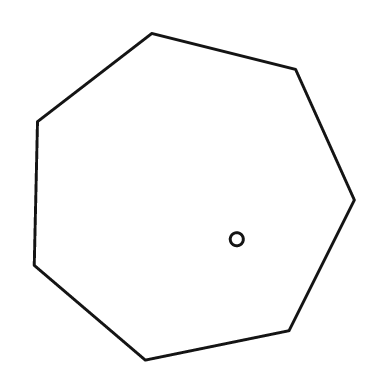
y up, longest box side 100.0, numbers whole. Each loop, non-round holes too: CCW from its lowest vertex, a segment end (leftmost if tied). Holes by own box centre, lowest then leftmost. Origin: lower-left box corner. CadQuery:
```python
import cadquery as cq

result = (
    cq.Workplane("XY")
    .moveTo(34.0, 0.0)
    .lineTo(78.0, 9.0)
    .lineTo(98.0, 49.0)
    .lineTo(80.0, 89.0)
    .lineTo(36.0, 100.0)
    .lineTo(1.0, 73.0)
    .lineTo(0.0, 29.0)
    .close()
    .moveTo(62.0, 37.0)
    .circle(2.0)
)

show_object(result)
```